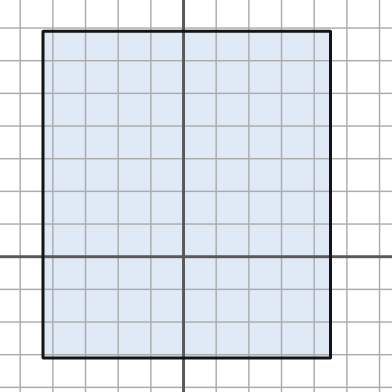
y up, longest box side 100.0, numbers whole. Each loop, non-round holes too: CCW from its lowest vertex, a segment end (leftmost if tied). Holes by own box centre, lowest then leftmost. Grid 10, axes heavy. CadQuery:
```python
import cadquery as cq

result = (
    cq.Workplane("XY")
    .moveTo(-43.0, -31.0)
    .lineTo(45.0, -31.0)
    .lineTo(45.0, 69.0)
    .lineTo(-43.0, 69.0)
    .close()
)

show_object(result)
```